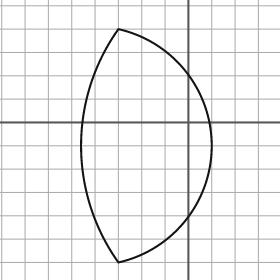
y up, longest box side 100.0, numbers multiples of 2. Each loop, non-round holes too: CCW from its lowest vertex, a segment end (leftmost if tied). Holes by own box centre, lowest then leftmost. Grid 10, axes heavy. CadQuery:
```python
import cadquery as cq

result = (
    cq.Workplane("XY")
    .moveTo(-30.0, -60.0)
    .threePointArc((10.0, -10.0), (-30.0, 40.0))
    .threePointArc((-46.0, -10.0), (-30.0, -60.0))
    .close()
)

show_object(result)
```